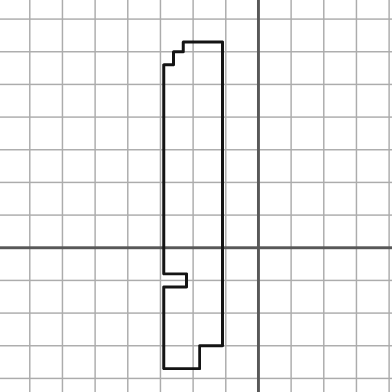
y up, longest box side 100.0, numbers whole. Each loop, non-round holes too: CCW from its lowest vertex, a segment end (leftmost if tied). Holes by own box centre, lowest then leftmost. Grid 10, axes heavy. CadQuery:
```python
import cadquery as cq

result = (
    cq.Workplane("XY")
    .moveTo(-29.0, -37.0)
    .lineTo(-18.0, -37.0)
    .lineTo(-18.0, -30.0)
    .lineTo(-11.0, -30.0)
    .lineTo(-11.0, 63.0)
    .lineTo(-23.0, 63.0)
    .lineTo(-23.0, 60.0)
    .lineTo(-26.0, 60.0)
    .lineTo(-26.0, 56.0)
    .lineTo(-29.0, 56.0)
    .lineTo(-29.0, -8.0)
    .lineTo(-22.0, -8.0)
    .lineTo(-22.0, -12.0)
    .lineTo(-29.0, -12.0)
    .close()
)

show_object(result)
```